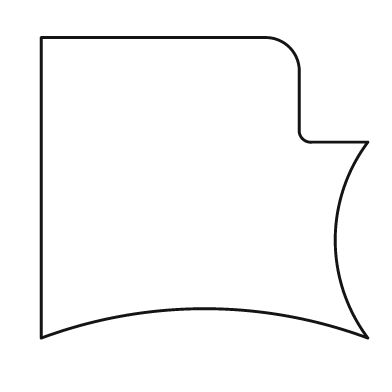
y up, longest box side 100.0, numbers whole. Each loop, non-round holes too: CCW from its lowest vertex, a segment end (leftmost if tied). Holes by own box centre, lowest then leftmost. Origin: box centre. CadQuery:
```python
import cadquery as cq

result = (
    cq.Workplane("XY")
    .moveTo(-50.0, -46.0)
    .threePointArc((0.0, -37.0), (50.0, -46.0))
    .threePointArc((40.0, -16.0), (50.0, 14.0))
    .lineTo(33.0, 14.0)
    .threePointArc((30.0, 15.0), (29.0, 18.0))
    .lineTo(29.0, 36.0)
    .threePointArc((26.0, 43.0), (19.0, 46.0))
    .lineTo(-50.0, 46.0)
    .close()
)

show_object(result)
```